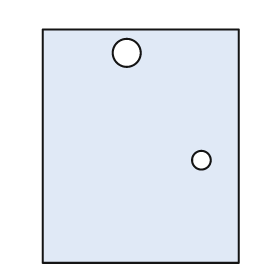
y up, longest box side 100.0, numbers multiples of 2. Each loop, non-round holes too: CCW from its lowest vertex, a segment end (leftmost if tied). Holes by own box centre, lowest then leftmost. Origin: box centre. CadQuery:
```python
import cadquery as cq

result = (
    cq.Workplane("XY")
    .moveTo(-42.0, -50.0)
    .lineTo(42.0, -50.0)
    .lineTo(42.0, 50.0)
    .lineTo(-42.0, 50.0)
    .close()
    .moveTo(26.0, -6.0)
    .circle(4.0)
    .moveTo(-6.0, 40.0)
    .circle(6.0)
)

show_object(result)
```